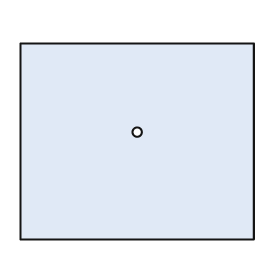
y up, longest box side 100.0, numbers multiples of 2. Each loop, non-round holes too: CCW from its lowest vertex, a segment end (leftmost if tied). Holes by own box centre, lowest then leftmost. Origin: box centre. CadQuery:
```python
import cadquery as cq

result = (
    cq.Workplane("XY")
    .moveTo(-50.0, -42.0)
    .lineTo(50.0, -42.0)
    .lineTo(50.0, 42.0)
    .lineTo(-50.0, 42.0)
    .close()
    .moveTo(0.0, 4.0)
    .circle(2.0)
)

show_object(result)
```